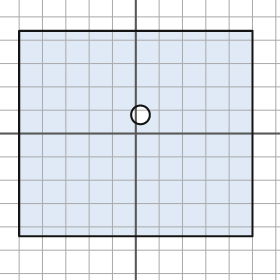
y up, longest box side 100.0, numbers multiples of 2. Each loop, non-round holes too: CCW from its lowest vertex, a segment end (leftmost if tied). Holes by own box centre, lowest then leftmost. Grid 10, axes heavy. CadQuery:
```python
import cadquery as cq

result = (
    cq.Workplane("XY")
    .moveTo(-50.0, -44.0)
    .lineTo(50.0, -44.0)
    .lineTo(50.0, 44.0)
    .lineTo(-50.0, 44.0)
    .close()
    .moveTo(2.0, 8.0)
    .circle(4.0)
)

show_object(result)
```